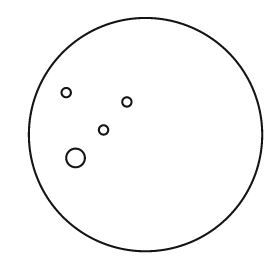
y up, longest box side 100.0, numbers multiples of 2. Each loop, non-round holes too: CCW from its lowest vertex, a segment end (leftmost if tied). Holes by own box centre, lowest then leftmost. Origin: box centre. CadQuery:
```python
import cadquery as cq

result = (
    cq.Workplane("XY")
    .moveTo(0.0, 0.0)
    .circle(50.0)
    .moveTo(-30.0, -10.0)
    .circle(4.0)
    .moveTo(-18.0, 2.0)
    .circle(2.0)
    .moveTo(-8.0, 14.0)
    .circle(2.0)
    .moveTo(-34.0, 18.0)
    .circle(2.0)
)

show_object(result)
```